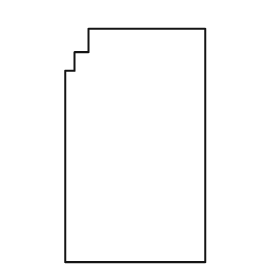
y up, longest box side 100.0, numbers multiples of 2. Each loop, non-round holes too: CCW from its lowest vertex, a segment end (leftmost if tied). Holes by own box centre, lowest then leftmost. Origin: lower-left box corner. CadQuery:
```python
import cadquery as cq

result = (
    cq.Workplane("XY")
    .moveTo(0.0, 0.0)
    .lineTo(60.0, 0.0)
    .lineTo(60.0, 100.0)
    .lineTo(10.0, 100.0)
    .lineTo(10.0, 90.0)
    .lineTo(4.0, 90.0)
    .lineTo(4.0, 82.0)
    .lineTo(0.0, 82.0)
    .close()
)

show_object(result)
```